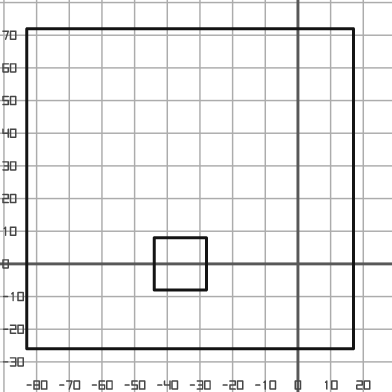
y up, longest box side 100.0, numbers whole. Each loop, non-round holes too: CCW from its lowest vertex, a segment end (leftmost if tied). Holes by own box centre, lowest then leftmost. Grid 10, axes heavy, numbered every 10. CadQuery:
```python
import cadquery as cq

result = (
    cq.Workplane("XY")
    .moveTo(-83.0, -26.0)
    .lineTo(17.0, -26.0)
    .lineTo(17.0, 72.0)
    .lineTo(-83.0, 72.0)
    .close()
    .moveTo(-44.0, -8.0)
    .lineTo(-28.0, -8.0)
    .lineTo(-28.0, 8.0)
    .lineTo(-44.0, 8.0)
    .close()
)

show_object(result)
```